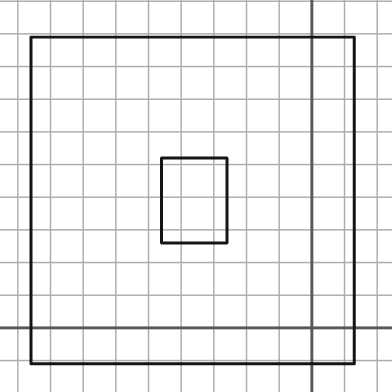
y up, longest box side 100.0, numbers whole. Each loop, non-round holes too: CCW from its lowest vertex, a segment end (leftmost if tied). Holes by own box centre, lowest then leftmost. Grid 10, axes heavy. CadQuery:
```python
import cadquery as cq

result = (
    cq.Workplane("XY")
    .moveTo(-86.0, -11.0)
    .lineTo(13.0, -11.0)
    .lineTo(13.0, 89.0)
    .lineTo(-86.0, 89.0)
    .close()
    .moveTo(-46.0, 26.0)
    .lineTo(-26.0, 26.0)
    .lineTo(-26.0, 52.0)
    .lineTo(-46.0, 52.0)
    .close()
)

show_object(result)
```